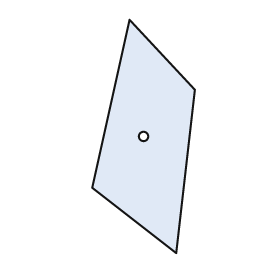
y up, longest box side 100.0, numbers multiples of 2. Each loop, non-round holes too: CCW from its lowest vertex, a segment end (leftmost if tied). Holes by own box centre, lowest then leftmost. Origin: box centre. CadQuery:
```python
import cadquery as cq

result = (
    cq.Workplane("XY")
    .moveTo(14.0, -50.0)
    .lineTo(22.0, 20.0)
    .lineTo(-6.0, 50.0)
    .lineTo(-22.0, -22.0)
    .close()
    .moveTo(0.0, 0.0)
    .circle(2.0)
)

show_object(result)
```